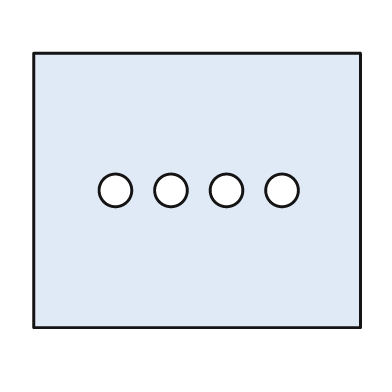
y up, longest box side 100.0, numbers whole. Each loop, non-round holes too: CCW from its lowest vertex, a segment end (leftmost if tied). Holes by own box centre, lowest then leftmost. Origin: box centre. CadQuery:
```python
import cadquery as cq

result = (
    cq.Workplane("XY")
    .moveTo(-50.0, -42.0)
    .lineTo(50.0, -42.0)
    .lineTo(50.0, 42.0)
    .lineTo(-50.0, 42.0)
    .close()
    .moveTo(-25.0, 0.0)
    .circle(5.0)
    .moveTo(-8.0, 0.0)
    .circle(5.0)
    .moveTo(9.0, 0.0)
    .circle(5.0)
    .moveTo(26.0, 0.0)
    .circle(5.0)
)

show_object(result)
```